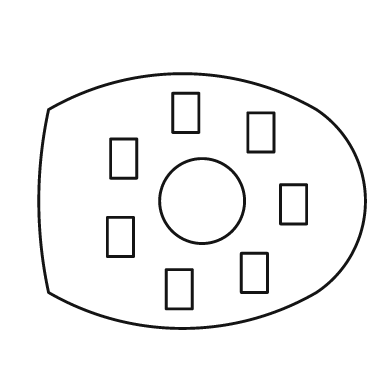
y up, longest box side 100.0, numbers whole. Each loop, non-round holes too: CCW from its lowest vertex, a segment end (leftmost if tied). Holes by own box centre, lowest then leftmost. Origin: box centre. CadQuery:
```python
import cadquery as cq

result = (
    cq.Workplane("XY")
    .moveTo(-47.0, -28.0)
    .threePointArc((-6.0, -39.0), (35.0, -28.0))
    .threePointArc((50.0, 0.0), (35.0, 28.0))
    .threePointArc((-6.0, 39.0), (-47.0, 28.0))
    .threePointArc((-50.0, 0.0), (-47.0, -28.0))
    .close()
    .moveTo(-11.0, -33.0)
    .lineTo(-3.0, -33.0)
    .lineTo(-3.0, -21.0)
    .lineTo(-11.0, -21.0)
    .close()
    .moveTo(12.0, -28.0)
    .lineTo(20.0, -28.0)
    .lineTo(20.0, -16.0)
    .lineTo(12.0, -16.0)
    .close()
    .moveTo(-29.0, -17.0)
    .lineTo(-21.0, -17.0)
    .lineTo(-21.0, -5.0)
    .lineTo(-29.0, -5.0)
    .close()
    .moveTo(24.0, -7.0)
    .lineTo(32.0, -7.0)
    .lineTo(32.0, 5.0)
    .lineTo(24.0, 5.0)
    .close()
    .moveTo(0.0, 0.0)
    .circle(13.0)
    .moveTo(-28.0, 7.0)
    .lineTo(-20.0, 7.0)
    .lineTo(-20.0, 19.0)
    .lineTo(-28.0, 19.0)
    .close()
    .moveTo(14.0, 15.0)
    .lineTo(22.0, 15.0)
    .lineTo(22.0, 27.0)
    .lineTo(14.0, 27.0)
    .close()
    .moveTo(-9.0, 21.0)
    .lineTo(-1.0, 21.0)
    .lineTo(-1.0, 33.0)
    .lineTo(-9.0, 33.0)
    .close()
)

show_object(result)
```